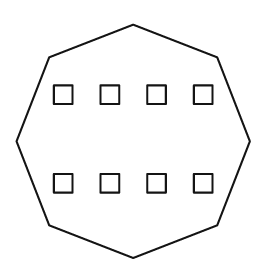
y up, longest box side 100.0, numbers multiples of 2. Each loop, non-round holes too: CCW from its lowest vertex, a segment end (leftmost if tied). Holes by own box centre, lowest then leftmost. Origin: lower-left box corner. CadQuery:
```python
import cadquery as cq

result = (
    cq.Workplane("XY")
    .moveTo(50.0, 0.0)
    .lineTo(86.0, 14.0)
    .lineTo(100.0, 50.0)
    .lineTo(86.0, 86.0)
    .lineTo(50.0, 100.0)
    .lineTo(14.0, 86.0)
    .lineTo(0.0, 50.0)
    .lineTo(14.0, 14.0)
    .close()
    .moveTo(16.0, 28.0)
    .lineTo(24.0, 28.0)
    .lineTo(24.0, 36.0)
    .lineTo(16.0, 36.0)
    .close()
    .moveTo(36.0, 28.0)
    .lineTo(44.0, 28.0)
    .lineTo(44.0, 36.0)
    .lineTo(36.0, 36.0)
    .close()
    .moveTo(56.0, 28.0)
    .lineTo(64.0, 28.0)
    .lineTo(64.0, 36.0)
    .lineTo(56.0, 36.0)
    .close()
    .moveTo(76.0, 28.0)
    .lineTo(84.0, 28.0)
    .lineTo(84.0, 36.0)
    .lineTo(76.0, 36.0)
    .close()
    .moveTo(16.0, 66.0)
    .lineTo(24.0, 66.0)
    .lineTo(24.0, 74.0)
    .lineTo(16.0, 74.0)
    .close()
    .moveTo(36.0, 66.0)
    .lineTo(44.0, 66.0)
    .lineTo(44.0, 74.0)
    .lineTo(36.0, 74.0)
    .close()
    .moveTo(56.0, 66.0)
    .lineTo(64.0, 66.0)
    .lineTo(64.0, 74.0)
    .lineTo(56.0, 74.0)
    .close()
    .moveTo(76.0, 66.0)
    .lineTo(84.0, 66.0)
    .lineTo(84.0, 74.0)
    .lineTo(76.0, 74.0)
    .close()
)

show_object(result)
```